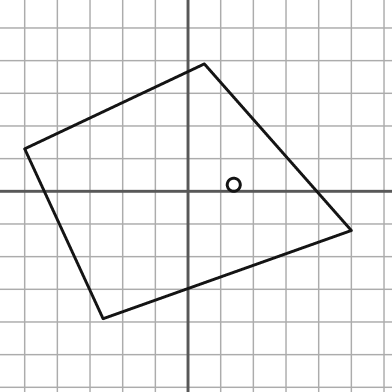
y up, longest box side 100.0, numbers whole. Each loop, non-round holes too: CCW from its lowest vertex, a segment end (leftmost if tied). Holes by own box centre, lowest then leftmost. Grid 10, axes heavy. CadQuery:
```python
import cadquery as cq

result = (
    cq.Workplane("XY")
    .moveTo(-26.0, -39.0)
    .lineTo(50.0, -12.0)
    .lineTo(5.0, 39.0)
    .lineTo(-50.0, 13.0)
    .close()
    .moveTo(14.0, 2.0)
    .circle(2.0)
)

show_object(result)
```